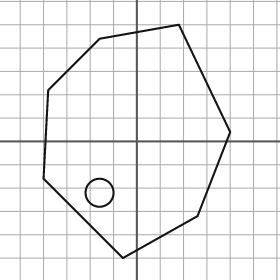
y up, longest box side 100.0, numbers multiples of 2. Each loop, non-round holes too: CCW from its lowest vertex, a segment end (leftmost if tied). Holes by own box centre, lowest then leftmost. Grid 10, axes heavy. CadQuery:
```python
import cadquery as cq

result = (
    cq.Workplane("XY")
    .moveTo(-6.0, -50.0)
    .lineTo(26.0, -32.0)
    .lineTo(40.0, 4.0)
    .lineTo(18.0, 50.0)
    .lineTo(-16.0, 44.0)
    .lineTo(-38.0, 22.0)
    .lineTo(-40.0, -16.0)
    .close()
    .moveTo(-16.0, -22.0)
    .circle(6.0)
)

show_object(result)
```